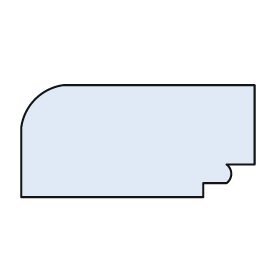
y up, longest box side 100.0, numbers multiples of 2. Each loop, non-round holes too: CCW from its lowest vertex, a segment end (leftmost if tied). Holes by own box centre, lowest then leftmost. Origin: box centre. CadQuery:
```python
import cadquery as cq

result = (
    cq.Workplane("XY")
    .moveTo(-50.0, -24.0)
    .lineTo(28.0, -24.0)
    .lineTo(28.0, -18.0)
    .lineTo(38.0, -18.0)
    .threePointArc((40.0, -14.0), (38.0, -10.0))
    .lineTo(50.0, -10.0)
    .lineTo(50.0, 24.0)
    .lineTo(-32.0, 24.0)
    .threePointArc((-44.0, 18.0), (-50.0, 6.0))
    .close()
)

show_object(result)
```